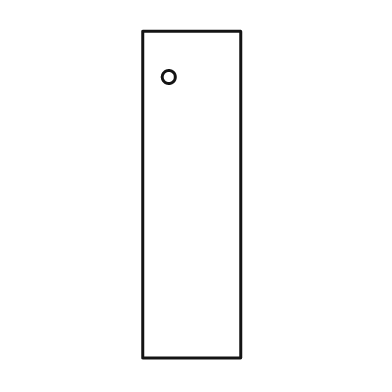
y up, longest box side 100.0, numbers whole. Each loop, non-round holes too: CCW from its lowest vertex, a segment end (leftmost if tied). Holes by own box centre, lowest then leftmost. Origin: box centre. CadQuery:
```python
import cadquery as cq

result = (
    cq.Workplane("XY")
    .moveTo(-15.0, -50.0)
    .lineTo(15.0, -50.0)
    .lineTo(15.0, 50.0)
    .lineTo(-15.0, 50.0)
    .close()
    .moveTo(-7.0, 36.0)
    .circle(2.0)
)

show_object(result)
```